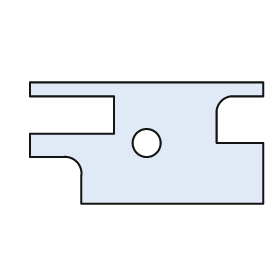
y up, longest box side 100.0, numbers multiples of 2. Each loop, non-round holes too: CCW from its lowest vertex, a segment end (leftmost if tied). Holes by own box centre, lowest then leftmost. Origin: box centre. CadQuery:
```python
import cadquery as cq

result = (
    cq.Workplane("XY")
    .moveTo(-28.0, -26.0)
    .lineTo(50.0, -26.0)
    .lineTo(50.0, 0.0)
    .lineTo(30.0, 0.0)
    .lineTo(30.0, 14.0)
    .threePointArc((32.0, 18.0), (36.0, 20.0))
    .lineTo(50.0, 20.0)
    .lineTo(50.0, 26.0)
    .lineTo(-50.0, 26.0)
    .lineTo(-50.0, 20.0)
    .lineTo(-14.0, 20.0)
    .lineTo(-14.0, 4.0)
    .lineTo(-50.0, 4.0)
    .lineTo(-50.0, -6.0)
    .lineTo(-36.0, -6.0)
    .threePointArc((-30.0, -8.0), (-28.0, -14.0))
    .close()
    .moveTo(0.0, 0.0)
    .circle(6.0)
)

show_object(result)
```